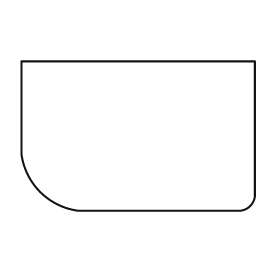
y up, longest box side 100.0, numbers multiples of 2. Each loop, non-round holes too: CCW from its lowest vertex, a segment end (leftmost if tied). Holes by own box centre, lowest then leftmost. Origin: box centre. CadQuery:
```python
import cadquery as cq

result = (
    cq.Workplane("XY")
    .moveTo(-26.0, -32.0)
    .lineTo(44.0, -32.0)
    .threePointArc((48.0, -30.0), (50.0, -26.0))
    .lineTo(50.0, 32.0)
    .lineTo(-50.0, 32.0)
    .lineTo(-50.0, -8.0)
    .threePointArc((-42.0, -24.0), (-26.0, -32.0))
    .close()
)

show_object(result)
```